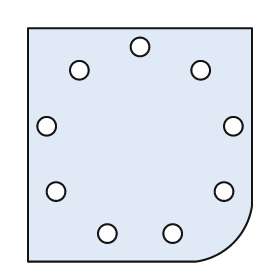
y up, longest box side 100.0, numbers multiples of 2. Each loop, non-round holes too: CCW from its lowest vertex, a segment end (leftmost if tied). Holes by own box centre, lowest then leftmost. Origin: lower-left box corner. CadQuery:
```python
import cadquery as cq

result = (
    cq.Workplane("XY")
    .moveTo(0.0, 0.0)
    .lineTo(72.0, 0.0)
    .threePointArc((88.0, 8.0), (96.0, 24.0))
    .lineTo(96.0, 100.0)
    .lineTo(0.0, 100.0)
    .close()
    .moveTo(34.0, 12.0)
    .circle(4.0)
    .moveTo(62.0, 12.0)
    .circle(4.0)
    .moveTo(12.0, 30.0)
    .circle(4.0)
    .moveTo(84.0, 30.0)
    .circle(4.0)
    .moveTo(8.0, 58.0)
    .circle(4.0)
    .moveTo(88.0, 58.0)
    .circle(4.0)
    .moveTo(22.0, 82.0)
    .circle(4.0)
    .moveTo(74.0, 82.0)
    .circle(4.0)
    .moveTo(48.0, 92.0)
    .circle(4.0)
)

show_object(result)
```